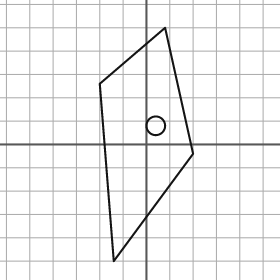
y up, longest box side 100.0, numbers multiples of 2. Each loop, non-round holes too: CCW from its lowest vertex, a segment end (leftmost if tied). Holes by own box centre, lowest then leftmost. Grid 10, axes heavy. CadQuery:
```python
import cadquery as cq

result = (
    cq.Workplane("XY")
    .moveTo(-14.0, -50.0)
    .lineTo(20.0, -4.0)
    .lineTo(8.0, 50.0)
    .lineTo(-20.0, 26.0)
    .close()
    .moveTo(4.0, 8.0)
    .circle(4.0)
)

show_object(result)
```